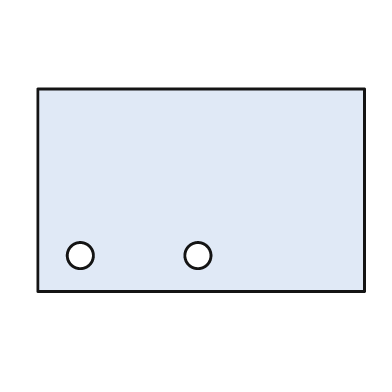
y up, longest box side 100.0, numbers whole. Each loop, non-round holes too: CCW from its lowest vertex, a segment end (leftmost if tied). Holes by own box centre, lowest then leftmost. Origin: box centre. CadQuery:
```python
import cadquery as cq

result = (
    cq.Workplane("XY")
    .moveTo(-50.0, -31.0)
    .lineTo(50.0, -31.0)
    .lineTo(50.0, 31.0)
    .lineTo(-50.0, 31.0)
    .close()
    .moveTo(-37.0, -20.0)
    .circle(4.0)
    .moveTo(-1.0, -20.0)
    .circle(4.0)
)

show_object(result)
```